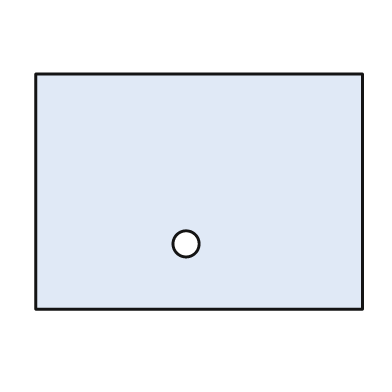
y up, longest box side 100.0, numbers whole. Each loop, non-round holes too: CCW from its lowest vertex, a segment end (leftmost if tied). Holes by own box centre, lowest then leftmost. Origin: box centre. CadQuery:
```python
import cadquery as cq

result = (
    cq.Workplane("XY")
    .moveTo(-50.0, -36.0)
    .lineTo(50.0, -36.0)
    .lineTo(50.0, 36.0)
    .lineTo(-50.0, 36.0)
    .close()
    .moveTo(-4.0, -16.0)
    .circle(4.0)
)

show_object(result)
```